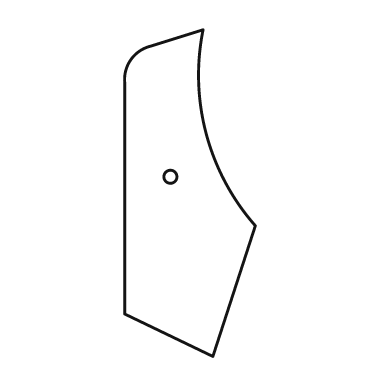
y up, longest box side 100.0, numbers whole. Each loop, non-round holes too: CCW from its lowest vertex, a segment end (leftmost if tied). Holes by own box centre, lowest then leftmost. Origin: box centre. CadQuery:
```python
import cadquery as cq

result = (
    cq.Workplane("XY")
    .moveTo(7.0, -50.0)
    .lineTo(20.0, -10.0)
    .threePointArc((5.0, 18.0), (4.0, 50.0))
    .lineTo(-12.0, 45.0)
    .threePointArc((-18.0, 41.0), (-20.0, 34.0))
    .lineTo(-20.0, -37.0)
    .close()
    .moveTo(-6.0, 5.0)
    .circle(2.0)
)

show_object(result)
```